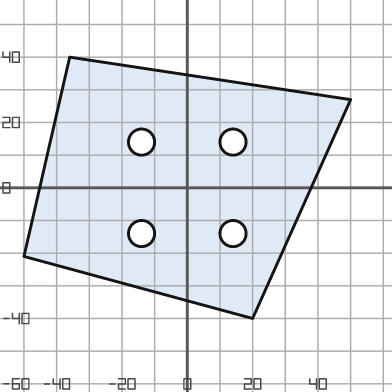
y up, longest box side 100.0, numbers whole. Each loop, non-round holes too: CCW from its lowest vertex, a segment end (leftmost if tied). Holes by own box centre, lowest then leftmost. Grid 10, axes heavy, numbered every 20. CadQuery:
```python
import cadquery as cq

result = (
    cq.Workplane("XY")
    .moveTo(20.0, -40.0)
    .lineTo(50.0, 27.0)
    .lineTo(-36.0, 40.0)
    .lineTo(-50.0, -21.0)
    .close()
    .moveTo(-14.0, -14.0)
    .circle(4.0)
    .moveTo(14.0, -14.0)
    .circle(4.0)
    .moveTo(-14.0, 14.0)
    .circle(4.0)
    .moveTo(14.0, 14.0)
    .circle(4.0)
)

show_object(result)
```